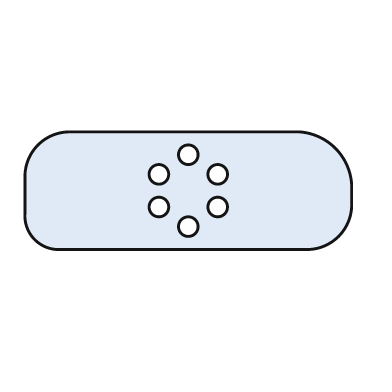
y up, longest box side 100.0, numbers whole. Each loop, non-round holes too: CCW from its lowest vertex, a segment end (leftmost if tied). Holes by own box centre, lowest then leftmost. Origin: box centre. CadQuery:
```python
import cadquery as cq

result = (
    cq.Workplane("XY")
    .moveTo(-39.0, -18.0)
    .lineTo(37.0, -18.0)
    .threePointArc((46.0, -14.0), (50.0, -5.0))
    .lineTo(50.0, 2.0)
    .threePointArc((45.0, 13.0), (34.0, 18.0))
    .lineTo(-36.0, 18.0)
    .threePointArc((-46.0, 14.0), (-50.0, 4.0))
    .lineTo(-50.0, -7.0)
    .threePointArc((-47.0, -15.0), (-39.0, -18.0))
    .close()
    .moveTo(0.0, -11.0)
    .circle(3.0)
    .moveTo(-9.0, -5.0)
    .circle(3.0)
    .moveTo(9.0, -5.0)
    .circle(3.0)
    .moveTo(-9.0, 5.0)
    .circle(3.0)
    .moveTo(9.0, 5.0)
    .circle(3.0)
    .moveTo(0.0, 11.0)
    .circle(3.0)
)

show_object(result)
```